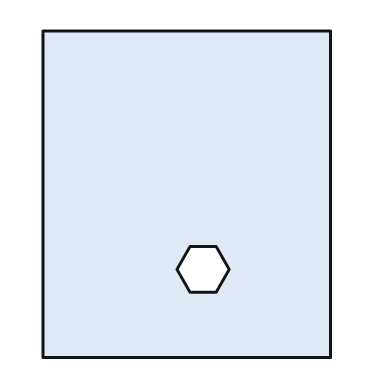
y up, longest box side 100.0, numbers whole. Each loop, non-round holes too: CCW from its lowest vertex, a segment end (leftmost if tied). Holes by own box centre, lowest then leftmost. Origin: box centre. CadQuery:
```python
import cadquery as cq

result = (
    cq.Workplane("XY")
    .moveTo(-44.0, -50.0)
    .lineTo(44.0, -50.0)
    .lineTo(44.0, 50.0)
    .lineTo(-44.0, 50.0)
    .close()
    .moveTo(1.0, -30.0)
    .lineTo(9.0, -30.0)
    .lineTo(13.0, -23.0)
    .lineTo(9.0, -16.0)
    .lineTo(1.0, -16.0)
    .lineTo(-3.0, -23.0)
    .close()
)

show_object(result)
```